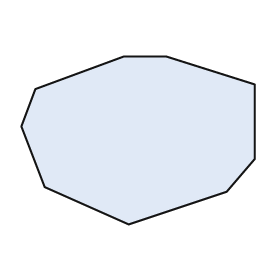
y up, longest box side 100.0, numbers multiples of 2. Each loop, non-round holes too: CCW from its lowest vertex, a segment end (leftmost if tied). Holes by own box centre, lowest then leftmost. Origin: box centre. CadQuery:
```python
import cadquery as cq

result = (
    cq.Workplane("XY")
    .moveTo(-4.0, -36.0)
    .lineTo(38.0, -22.0)
    .lineTo(50.0, -8.0)
    .lineTo(50.0, 24.0)
    .lineTo(12.0, 36.0)
    .lineTo(-6.0, 36.0)
    .lineTo(-44.0, 22.0)
    .lineTo(-50.0, 6.0)
    .lineTo(-40.0, -20.0)
    .close()
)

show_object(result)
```